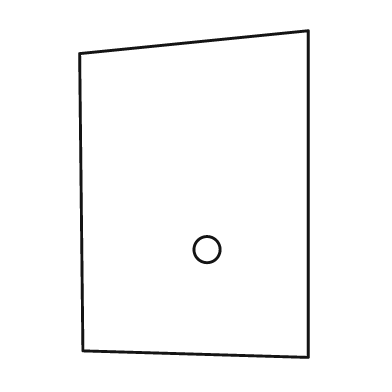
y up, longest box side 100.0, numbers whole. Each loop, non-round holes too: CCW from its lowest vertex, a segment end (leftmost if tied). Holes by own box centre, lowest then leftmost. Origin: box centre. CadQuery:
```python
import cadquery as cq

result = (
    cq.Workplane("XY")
    .moveTo(35.0, -50.0)
    .lineTo(35.0, 50.0)
    .lineTo(-35.0, 43.0)
    .lineTo(-34.0, -48.0)
    .close()
    .moveTo(4.0, -17.0)
    .circle(4.0)
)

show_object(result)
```